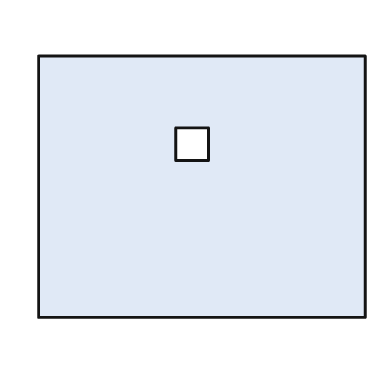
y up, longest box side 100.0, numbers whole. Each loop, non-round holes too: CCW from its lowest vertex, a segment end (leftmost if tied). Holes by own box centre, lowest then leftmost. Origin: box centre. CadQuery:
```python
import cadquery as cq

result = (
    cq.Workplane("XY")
    .moveTo(-50.0, -40.0)
    .lineTo(50.0, -40.0)
    .lineTo(50.0, 40.0)
    .lineTo(-50.0, 40.0)
    .close()
    .moveTo(-8.0, 8.0)
    .lineTo(2.0, 8.0)
    .lineTo(2.0, 18.0)
    .lineTo(-8.0, 18.0)
    .close()
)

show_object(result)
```